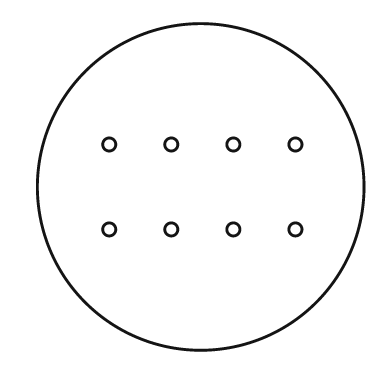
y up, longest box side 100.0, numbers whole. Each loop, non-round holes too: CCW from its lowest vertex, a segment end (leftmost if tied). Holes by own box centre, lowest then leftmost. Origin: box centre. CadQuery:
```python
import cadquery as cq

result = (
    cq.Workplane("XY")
    .moveTo(0.0, 0.0)
    .circle(50.0)
    .moveTo(-28.0, -13.0)
    .circle(2.0)
    .moveTo(-9.0, -13.0)
    .circle(2.0)
    .moveTo(10.0, -13.0)
    .circle(2.0)
    .moveTo(29.0, -13.0)
    .circle(2.0)
    .moveTo(-28.0, 13.0)
    .circle(2.0)
    .moveTo(-9.0, 13.0)
    .circle(2.0)
    .moveTo(10.0, 13.0)
    .circle(2.0)
    .moveTo(29.0, 13.0)
    .circle(2.0)
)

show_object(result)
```